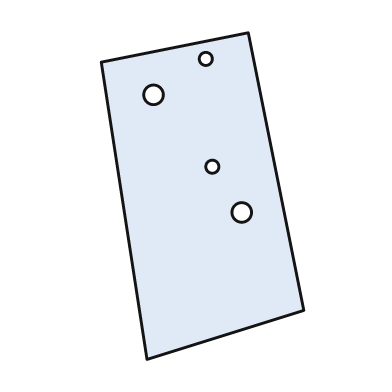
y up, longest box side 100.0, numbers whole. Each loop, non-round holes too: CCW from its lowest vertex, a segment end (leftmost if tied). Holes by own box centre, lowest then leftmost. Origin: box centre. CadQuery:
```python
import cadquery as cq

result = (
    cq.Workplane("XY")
    .moveTo(-17.0, -50.0)
    .lineTo(31.0, -35.0)
    .lineTo(14.0, 50.0)
    .lineTo(-31.0, 41.0)
    .close()
    .moveTo(12.0, -5.0)
    .circle(3.0)
    .moveTo(3.0, 9.0)
    .circle(2.0)
    .moveTo(-15.0, 31.0)
    .circle(3.0)
    .moveTo(1.0, 42.0)
    .circle(2.0)
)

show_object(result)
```